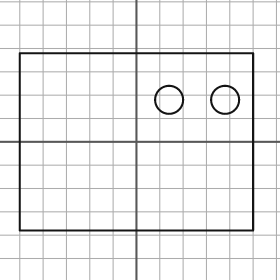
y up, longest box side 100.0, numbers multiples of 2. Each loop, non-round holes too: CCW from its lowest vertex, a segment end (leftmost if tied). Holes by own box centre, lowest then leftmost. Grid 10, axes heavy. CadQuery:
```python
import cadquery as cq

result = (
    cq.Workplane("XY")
    .moveTo(-50.0, -38.0)
    .lineTo(50.0, -38.0)
    .lineTo(50.0, 38.0)
    .lineTo(-50.0, 38.0)
    .close()
    .moveTo(14.0, 18.0)
    .circle(6.0)
    .moveTo(38.0, 18.0)
    .circle(6.0)
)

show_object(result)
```